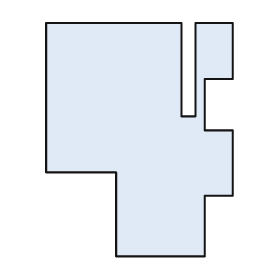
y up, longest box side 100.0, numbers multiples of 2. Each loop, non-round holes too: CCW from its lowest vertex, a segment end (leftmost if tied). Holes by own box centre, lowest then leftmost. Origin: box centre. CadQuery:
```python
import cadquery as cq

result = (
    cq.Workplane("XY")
    .moveTo(-10.0, -50.0)
    .lineTo(28.0, -50.0)
    .lineTo(28.0, -24.0)
    .lineTo(40.0, -24.0)
    .lineTo(40.0, 4.0)
    .lineTo(28.0, 4.0)
    .lineTo(28.0, 26.0)
    .lineTo(40.0, 26.0)
    .lineTo(40.0, 50.0)
    .lineTo(24.0, 50.0)
    .lineTo(24.0, 10.0)
    .lineTo(18.0, 10.0)
    .lineTo(18.0, 50.0)
    .lineTo(-40.0, 50.0)
    .lineTo(-40.0, -14.0)
    .lineTo(-10.0, -14.0)
    .close()
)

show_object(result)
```